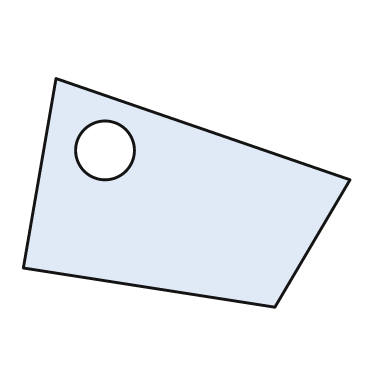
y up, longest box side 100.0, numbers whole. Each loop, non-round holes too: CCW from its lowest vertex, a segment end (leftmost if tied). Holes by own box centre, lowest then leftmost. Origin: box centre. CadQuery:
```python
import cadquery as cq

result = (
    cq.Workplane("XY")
    .moveTo(27.0, -35.0)
    .lineTo(50.0, 4.0)
    .lineTo(-40.0, 35.0)
    .lineTo(-50.0, -23.0)
    .close()
    .moveTo(-25.0, 13.0)
    .circle(9.0)
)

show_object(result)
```